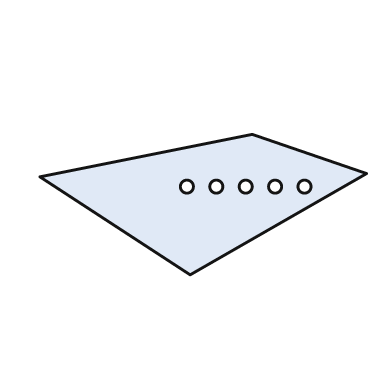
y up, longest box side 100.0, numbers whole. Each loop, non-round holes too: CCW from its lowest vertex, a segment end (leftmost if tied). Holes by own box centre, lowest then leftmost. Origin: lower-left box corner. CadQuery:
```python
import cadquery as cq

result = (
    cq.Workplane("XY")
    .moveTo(46.0, 0.0)
    .lineTo(100.0, 31.0)
    .lineTo(65.0, 43.0)
    .lineTo(0.0, 30.0)
    .close()
    .moveTo(45.0, 27.0)
    .circle(2.0)
    .moveTo(54.0, 27.0)
    .circle(2.0)
    .moveTo(63.0, 27.0)
    .circle(2.0)
    .moveTo(72.0, 27.0)
    .circle(2.0)
    .moveTo(81.0, 27.0)
    .circle(2.0)
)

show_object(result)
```